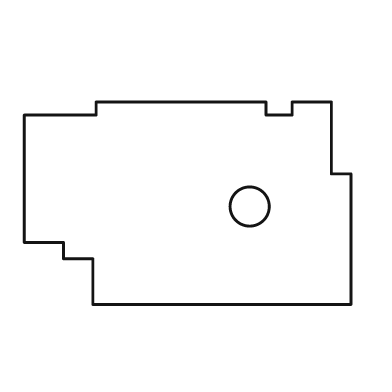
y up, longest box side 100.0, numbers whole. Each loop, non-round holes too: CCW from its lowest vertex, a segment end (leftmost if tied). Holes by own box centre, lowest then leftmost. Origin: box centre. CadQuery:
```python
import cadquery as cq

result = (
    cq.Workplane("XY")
    .moveTo(-29.0, -31.0)
    .lineTo(50.0, -31.0)
    .lineTo(50.0, 9.0)
    .lineTo(44.0, 9.0)
    .lineTo(44.0, 31.0)
    .lineTo(32.0, 31.0)
    .lineTo(32.0, 27.0)
    .lineTo(24.0, 27.0)
    .lineTo(24.0, 31.0)
    .lineTo(-28.0, 31.0)
    .lineTo(-28.0, 27.0)
    .lineTo(-50.0, 27.0)
    .lineTo(-50.0, -12.0)
    .lineTo(-38.0, -12.0)
    .lineTo(-38.0, -17.0)
    .lineTo(-29.0, -17.0)
    .close()
    .moveTo(19.0, -1.0)
    .circle(6.0)
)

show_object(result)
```